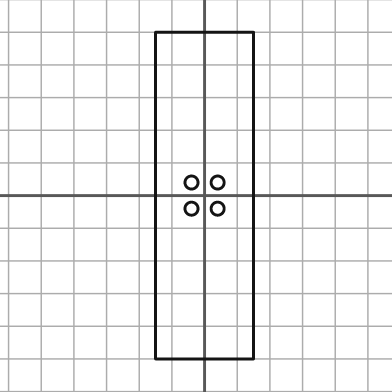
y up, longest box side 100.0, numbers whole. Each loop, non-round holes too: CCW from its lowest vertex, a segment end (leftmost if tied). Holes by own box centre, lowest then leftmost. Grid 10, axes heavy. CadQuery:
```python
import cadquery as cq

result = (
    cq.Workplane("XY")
    .moveTo(-15.0, -50.0)
    .lineTo(15.0, -50.0)
    .lineTo(15.0, 50.0)
    .lineTo(-15.0, 50.0)
    .close()
    .moveTo(-4.0, -4.0)
    .circle(2.0)
    .moveTo(4.0, -4.0)
    .circle(2.0)
    .moveTo(-4.0, 4.0)
    .circle(2.0)
    .moveTo(4.0, 4.0)
    .circle(2.0)
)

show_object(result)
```